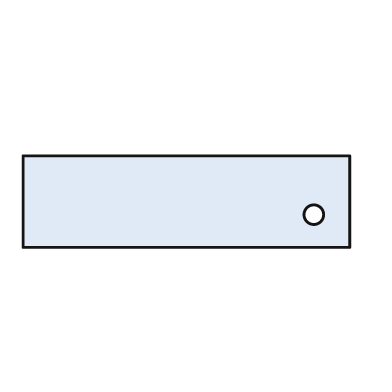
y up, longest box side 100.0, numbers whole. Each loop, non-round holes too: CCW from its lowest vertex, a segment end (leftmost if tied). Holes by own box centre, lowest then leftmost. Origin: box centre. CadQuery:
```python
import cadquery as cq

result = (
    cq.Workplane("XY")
    .moveTo(-50.0, -14.0)
    .lineTo(50.0, -14.0)
    .lineTo(50.0, 14.0)
    .lineTo(-50.0, 14.0)
    .close()
    .moveTo(39.0, -4.0)
    .circle(3.0)
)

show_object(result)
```